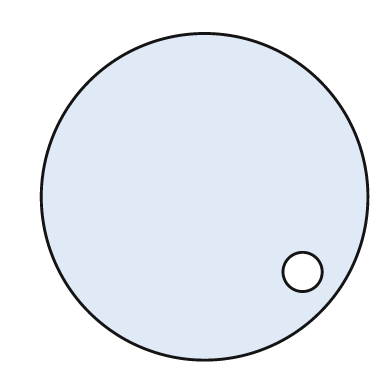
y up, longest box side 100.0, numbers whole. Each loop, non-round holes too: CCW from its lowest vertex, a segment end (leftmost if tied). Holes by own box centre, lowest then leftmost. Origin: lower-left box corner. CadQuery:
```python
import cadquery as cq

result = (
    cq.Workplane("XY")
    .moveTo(50.0, 50.0)
    .circle(50.0)
    .moveTo(80.0, 27.0)
    .circle(6.0)
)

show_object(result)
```